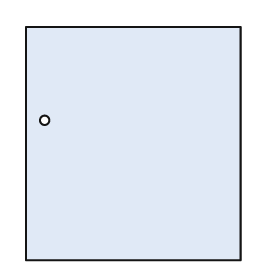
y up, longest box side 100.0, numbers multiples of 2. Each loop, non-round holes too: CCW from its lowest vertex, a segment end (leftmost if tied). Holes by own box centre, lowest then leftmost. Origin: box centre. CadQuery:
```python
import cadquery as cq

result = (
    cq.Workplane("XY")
    .moveTo(-46.0, -50.0)
    .lineTo(46.0, -50.0)
    .lineTo(46.0, 50.0)
    .lineTo(-46.0, 50.0)
    .close()
    .moveTo(-38.0, 10.0)
    .circle(2.0)
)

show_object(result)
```